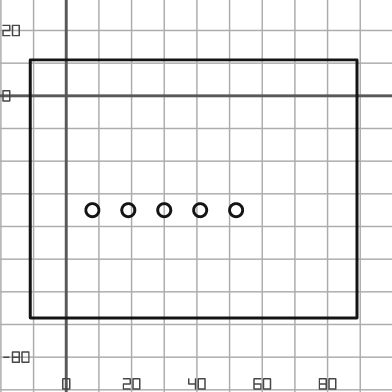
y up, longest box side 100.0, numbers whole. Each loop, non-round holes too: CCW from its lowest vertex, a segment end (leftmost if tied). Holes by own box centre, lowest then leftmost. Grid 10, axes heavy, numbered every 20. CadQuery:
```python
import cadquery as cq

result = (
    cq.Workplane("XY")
    .moveTo(-11.0, -68.0)
    .lineTo(89.0, -68.0)
    .lineTo(89.0, 11.0)
    .lineTo(-11.0, 11.0)
    .close()
    .moveTo(8.0, -35.0)
    .circle(2.0)
    .moveTo(19.0, -35.0)
    .circle(2.0)
    .moveTo(30.0, -35.0)
    .circle(2.0)
    .moveTo(41.0, -35.0)
    .circle(2.0)
    .moveTo(52.0, -35.0)
    .circle(2.0)
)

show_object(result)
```